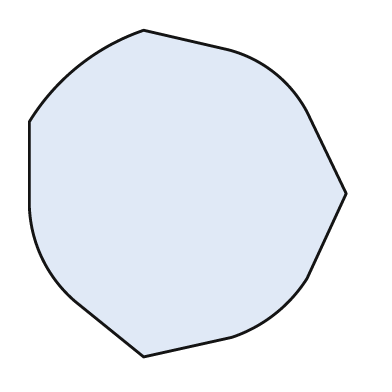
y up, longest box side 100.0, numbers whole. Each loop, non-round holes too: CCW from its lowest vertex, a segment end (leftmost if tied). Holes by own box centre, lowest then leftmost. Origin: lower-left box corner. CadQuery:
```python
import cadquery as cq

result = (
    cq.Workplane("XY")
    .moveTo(35.0, 0.0)
    .lineTo(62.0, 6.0)
    .threePointArc((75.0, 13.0), (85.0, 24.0))
    .lineTo(97.0, 50.0)
    .lineTo(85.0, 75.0)
    .threePointArc((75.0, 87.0), (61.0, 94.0))
    .lineTo(35.0, 100.0)
    .threePointArc((15.0, 89.0), (0.0, 72.0))
    .lineTo(0.0, 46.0)
    .threePointArc((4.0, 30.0), (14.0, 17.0))
    .close()
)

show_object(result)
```